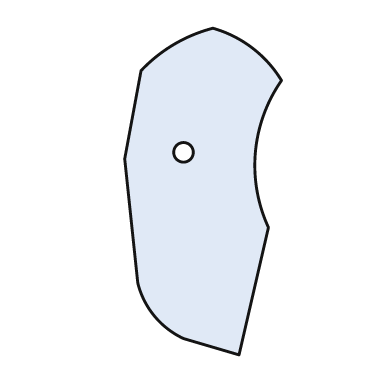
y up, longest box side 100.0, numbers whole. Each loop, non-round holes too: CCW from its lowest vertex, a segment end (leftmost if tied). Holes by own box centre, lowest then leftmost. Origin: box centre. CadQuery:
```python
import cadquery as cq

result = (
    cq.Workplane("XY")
    .moveTo(11.0, -50.0)
    .lineTo(20.0, -11.0)
    .threePointArc((16.0, 12.0), (24.0, 34.0))
    .threePointArc((15.0, 44.0), (3.0, 50.0))
    .threePointArc((-9.0, 45.0), (-19.0, 37.0))
    .lineTo(-24.0, 10.0)
    .lineTo(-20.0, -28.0)
    .threePointArc((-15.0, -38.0), (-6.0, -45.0))
    .close()
    .moveTo(-6.0, 12.0)
    .circle(3.0)
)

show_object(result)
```